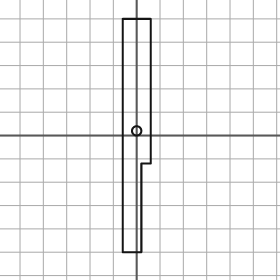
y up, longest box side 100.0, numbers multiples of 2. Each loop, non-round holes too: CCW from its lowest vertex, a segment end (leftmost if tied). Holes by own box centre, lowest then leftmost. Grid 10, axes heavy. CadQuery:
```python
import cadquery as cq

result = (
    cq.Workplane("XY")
    .moveTo(-6.0, -50.0)
    .lineTo(2.0, -50.0)
    .lineTo(2.0, -12.0)
    .lineTo(6.0, -12.0)
    .lineTo(6.0, 50.0)
    .lineTo(-6.0, 50.0)
    .close()
    .moveTo(0.0, 2.0)
    .circle(2.0)
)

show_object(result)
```